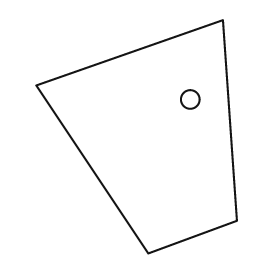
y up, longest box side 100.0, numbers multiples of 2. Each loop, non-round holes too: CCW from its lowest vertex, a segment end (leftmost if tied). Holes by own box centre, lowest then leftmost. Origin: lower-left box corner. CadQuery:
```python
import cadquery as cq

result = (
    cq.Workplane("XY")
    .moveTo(48.0, 0.0)
    .lineTo(86.0, 14.0)
    .lineTo(80.0, 100.0)
    .lineTo(0.0, 72.0)
    .close()
    .moveTo(66.0, 66.0)
    .circle(4.0)
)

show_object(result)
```